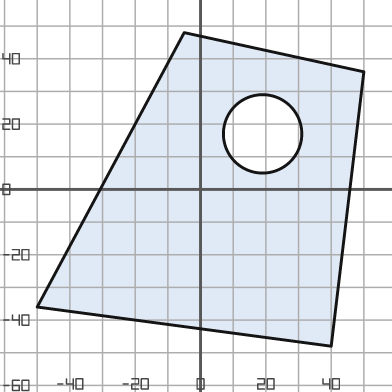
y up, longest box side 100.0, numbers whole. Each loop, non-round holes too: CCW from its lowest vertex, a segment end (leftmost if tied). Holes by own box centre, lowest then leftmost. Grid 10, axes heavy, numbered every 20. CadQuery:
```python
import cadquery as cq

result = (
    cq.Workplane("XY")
    .moveTo(40.0, -48.0)
    .lineTo(50.0, 36.0)
    .lineTo(-5.0, 48.0)
    .lineTo(-50.0, -36.0)
    .close()
    .moveTo(19.0, 17.0)
    .circle(12.0)
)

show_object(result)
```